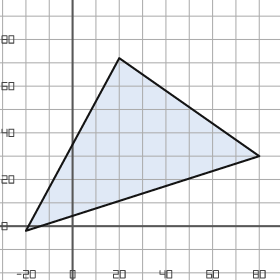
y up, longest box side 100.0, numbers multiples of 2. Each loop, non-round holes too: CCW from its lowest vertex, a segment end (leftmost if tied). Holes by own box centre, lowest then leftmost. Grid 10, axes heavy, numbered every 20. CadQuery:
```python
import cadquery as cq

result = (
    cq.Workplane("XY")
    .moveTo(-20.0, -2.0)
    .lineTo(80.0, 30.0)
    .lineTo(20.0, 72.0)
    .close()
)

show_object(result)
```